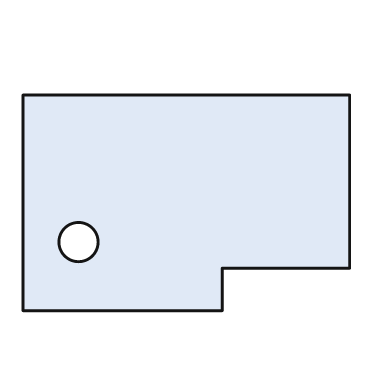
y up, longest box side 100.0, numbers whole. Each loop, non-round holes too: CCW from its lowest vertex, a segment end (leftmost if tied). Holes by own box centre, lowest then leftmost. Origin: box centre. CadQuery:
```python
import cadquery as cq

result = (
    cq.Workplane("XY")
    .moveTo(-50.0, -33.0)
    .lineTo(11.0, -33.0)
    .lineTo(11.0, -20.0)
    .lineTo(50.0, -20.0)
    .lineTo(50.0, 33.0)
    .lineTo(-50.0, 33.0)
    .close()
    .moveTo(-33.0, -12.0)
    .circle(6.0)
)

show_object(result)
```